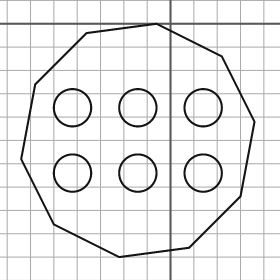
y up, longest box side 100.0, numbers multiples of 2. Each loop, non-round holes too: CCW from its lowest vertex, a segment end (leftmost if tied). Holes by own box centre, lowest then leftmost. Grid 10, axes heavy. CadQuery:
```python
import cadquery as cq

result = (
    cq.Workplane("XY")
    .moveTo(-22.0, -100.0)
    .lineTo(8.0, -96.0)
    .lineTo(30.0, -74.0)
    .lineTo(36.0, -42.0)
    .lineTo(22.0, -14.0)
    .lineTo(-6.0, 0.0)
    .lineTo(-36.0, -4.0)
    .lineTo(-58.0, -26.0)
    .lineTo(-64.0, -58.0)
    .lineTo(-50.0, -86.0)
    .close()
    .moveTo(-42.0, -64.0)
    .circle(8.0)
    .moveTo(-14.0, -64.0)
    .circle(8.0)
    .moveTo(14.0, -64.0)
    .circle(8.0)
    .moveTo(-42.0, -36.0)
    .circle(8.0)
    .moveTo(-14.0, -36.0)
    .circle(8.0)
    .moveTo(14.0, -36.0)
    .circle(8.0)
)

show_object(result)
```